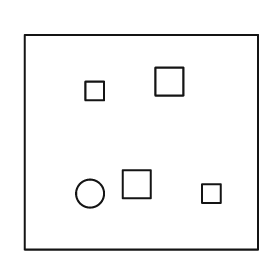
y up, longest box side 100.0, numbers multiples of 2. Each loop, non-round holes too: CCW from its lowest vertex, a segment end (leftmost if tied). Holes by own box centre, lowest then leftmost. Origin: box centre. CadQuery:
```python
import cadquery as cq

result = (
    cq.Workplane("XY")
    .moveTo(-50.0, -46.0)
    .lineTo(50.0, -46.0)
    .lineTo(50.0, 46.0)
    .lineTo(-50.0, 46.0)
    .close()
    .moveTo(-22.0, -22.0)
    .circle(6.0)
    .moveTo(26.0, -26.0)
    .lineTo(34.0, -26.0)
    .lineTo(34.0, -18.0)
    .lineTo(26.0, -18.0)
    .close()
    .moveTo(-8.0, -24.0)
    .lineTo(4.0, -24.0)
    .lineTo(4.0, -12.0)
    .lineTo(-8.0, -12.0)
    .close()
    .moveTo(-24.0, 18.0)
    .lineTo(-16.0, 18.0)
    .lineTo(-16.0, 26.0)
    .lineTo(-24.0, 26.0)
    .close()
    .moveTo(6.0, 20.0)
    .lineTo(18.0, 20.0)
    .lineTo(18.0, 32.0)
    .lineTo(6.0, 32.0)
    .close()
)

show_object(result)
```